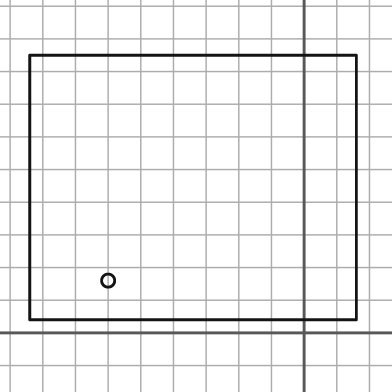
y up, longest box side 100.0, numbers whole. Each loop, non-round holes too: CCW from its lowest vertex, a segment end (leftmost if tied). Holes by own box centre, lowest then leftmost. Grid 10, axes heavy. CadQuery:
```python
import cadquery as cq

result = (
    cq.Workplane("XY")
    .moveTo(-84.0, 4.0)
    .lineTo(16.0, 4.0)
    .lineTo(16.0, 85.0)
    .lineTo(-84.0, 85.0)
    .close()
    .moveTo(-60.0, 16.0)
    .circle(2.0)
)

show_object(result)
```